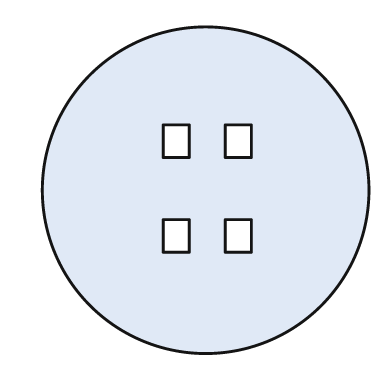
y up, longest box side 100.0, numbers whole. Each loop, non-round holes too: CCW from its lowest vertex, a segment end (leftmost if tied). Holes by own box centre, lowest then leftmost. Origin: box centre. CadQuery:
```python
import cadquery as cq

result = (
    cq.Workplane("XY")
    .moveTo(0.0, 0.0)
    .circle(50.0)
    .moveTo(-13.0, -19.0)
    .lineTo(-5.0, -19.0)
    .lineTo(-5.0, -9.0)
    .lineTo(-13.0, -9.0)
    .close()
    .moveTo(6.0, -19.0)
    .lineTo(14.0, -19.0)
    .lineTo(14.0, -9.0)
    .lineTo(6.0, -9.0)
    .close()
    .moveTo(-13.0, 10.0)
    .lineTo(-5.0, 10.0)
    .lineTo(-5.0, 20.0)
    .lineTo(-13.0, 20.0)
    .close()
    .moveTo(6.0, 10.0)
    .lineTo(14.0, 10.0)
    .lineTo(14.0, 20.0)
    .lineTo(6.0, 20.0)
    .close()
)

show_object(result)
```